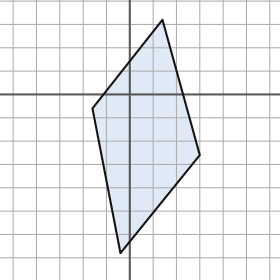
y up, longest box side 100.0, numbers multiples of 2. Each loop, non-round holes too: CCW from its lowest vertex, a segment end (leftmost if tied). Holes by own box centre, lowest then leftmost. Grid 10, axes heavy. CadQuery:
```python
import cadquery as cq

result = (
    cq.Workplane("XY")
    .moveTo(-4.0, -68.0)
    .lineTo(30.0, -26.0)
    .lineTo(14.0, 32.0)
    .lineTo(-16.0, -6.0)
    .close()
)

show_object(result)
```